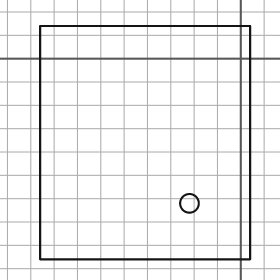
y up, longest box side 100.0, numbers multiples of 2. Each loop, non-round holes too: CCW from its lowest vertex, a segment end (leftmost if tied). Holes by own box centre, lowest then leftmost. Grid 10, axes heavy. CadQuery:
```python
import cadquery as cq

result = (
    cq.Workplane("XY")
    .moveTo(-86.0, -86.0)
    .lineTo(4.0, -86.0)
    .lineTo(4.0, 14.0)
    .lineTo(-86.0, 14.0)
    .close()
    .moveTo(-22.0, -62.0)
    .circle(4.0)
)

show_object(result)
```